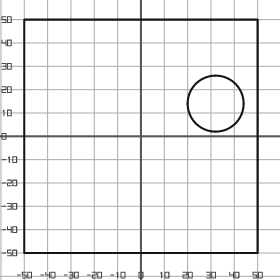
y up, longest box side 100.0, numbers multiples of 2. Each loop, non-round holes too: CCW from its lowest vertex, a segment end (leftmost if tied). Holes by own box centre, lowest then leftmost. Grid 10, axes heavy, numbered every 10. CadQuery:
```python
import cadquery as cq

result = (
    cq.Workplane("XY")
    .moveTo(-50.0, -50.0)
    .lineTo(50.0, -50.0)
    .lineTo(50.0, 50.0)
    .lineTo(-50.0, 50.0)
    .close()
    .moveTo(32.0, 14.0)
    .circle(12.0)
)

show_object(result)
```